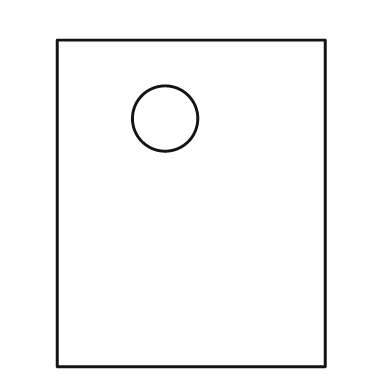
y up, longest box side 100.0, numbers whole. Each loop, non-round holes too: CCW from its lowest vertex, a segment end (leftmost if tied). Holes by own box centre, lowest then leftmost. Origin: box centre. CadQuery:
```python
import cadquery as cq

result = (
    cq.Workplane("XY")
    .moveTo(-41.0, -50.0)
    .lineTo(41.0, -50.0)
    .lineTo(41.0, 50.0)
    .lineTo(-41.0, 50.0)
    .close()
    .moveTo(-8.0, 26.0)
    .circle(10.0)
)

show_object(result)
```